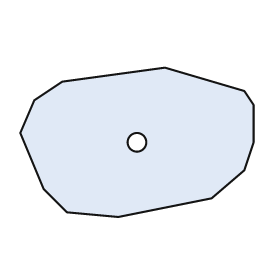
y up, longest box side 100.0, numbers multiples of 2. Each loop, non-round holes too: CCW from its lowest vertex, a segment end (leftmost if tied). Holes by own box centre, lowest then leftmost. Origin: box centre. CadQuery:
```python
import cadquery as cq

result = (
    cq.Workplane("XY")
    .moveTo(-8.0, -32.0)
    .lineTo(32.0, -24.0)
    .lineTo(46.0, -12.0)
    .lineTo(50.0, 0.0)
    .lineTo(50.0, 16.0)
    .lineTo(46.0, 22.0)
    .lineTo(12.0, 32.0)
    .lineTo(-32.0, 26.0)
    .lineTo(-44.0, 18.0)
    .lineTo(-50.0, 4.0)
    .lineTo(-40.0, -20.0)
    .lineTo(-30.0, -30.0)
    .close()
    .moveTo(0.0, 0.0)
    .circle(4.0)
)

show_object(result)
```